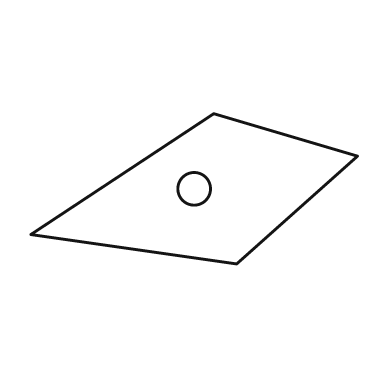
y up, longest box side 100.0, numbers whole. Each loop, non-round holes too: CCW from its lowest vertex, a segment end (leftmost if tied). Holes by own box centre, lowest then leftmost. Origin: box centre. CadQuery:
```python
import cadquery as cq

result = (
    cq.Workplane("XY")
    .moveTo(13.0, -23.0)
    .lineTo(50.0, 10.0)
    .lineTo(6.0, 23.0)
    .lineTo(-50.0, -14.0)
    .close()
    .moveTo(0.0, 0.0)
    .circle(5.0)
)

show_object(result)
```